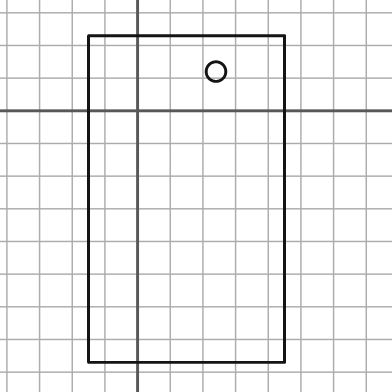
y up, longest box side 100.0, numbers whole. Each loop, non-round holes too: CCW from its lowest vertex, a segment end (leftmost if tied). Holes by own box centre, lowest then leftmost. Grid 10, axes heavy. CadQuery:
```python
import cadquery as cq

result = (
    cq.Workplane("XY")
    .moveTo(-15.0, -77.0)
    .lineTo(45.0, -77.0)
    .lineTo(45.0, 23.0)
    .lineTo(-15.0, 23.0)
    .close()
    .moveTo(24.0, 12.0)
    .circle(3.0)
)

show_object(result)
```